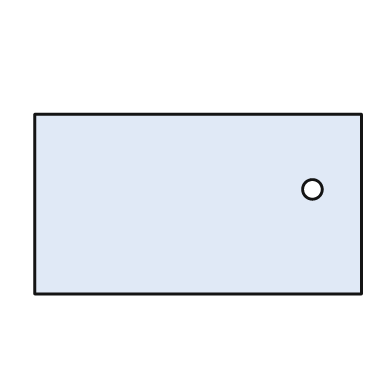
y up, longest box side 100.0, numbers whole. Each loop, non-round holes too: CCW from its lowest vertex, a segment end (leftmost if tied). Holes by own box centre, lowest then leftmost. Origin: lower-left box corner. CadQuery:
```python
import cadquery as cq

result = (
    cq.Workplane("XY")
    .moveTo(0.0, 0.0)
    .lineTo(100.0, 0.0)
    .lineTo(100.0, 55.0)
    .lineTo(0.0, 55.0)
    .close()
    .moveTo(85.0, 32.0)
    .circle(3.0)
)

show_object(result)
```